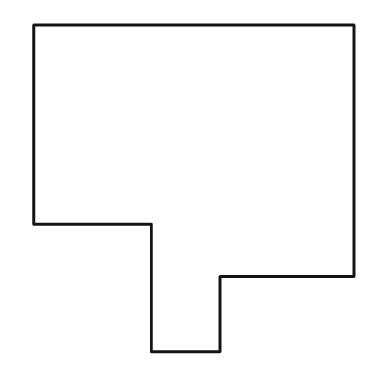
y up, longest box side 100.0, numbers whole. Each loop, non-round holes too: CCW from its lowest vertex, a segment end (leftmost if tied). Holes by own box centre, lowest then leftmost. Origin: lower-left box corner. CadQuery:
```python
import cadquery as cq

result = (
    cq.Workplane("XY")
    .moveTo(36.0, 0.0)
    .lineTo(57.0, 0.0)
    .lineTo(57.0, 23.0)
    .lineTo(98.0, 23.0)
    .lineTo(98.0, 100.0)
    .lineTo(0.0, 100.0)
    .lineTo(0.0, 39.0)
    .lineTo(36.0, 39.0)
    .close()
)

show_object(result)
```